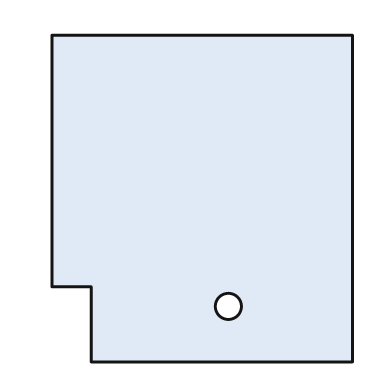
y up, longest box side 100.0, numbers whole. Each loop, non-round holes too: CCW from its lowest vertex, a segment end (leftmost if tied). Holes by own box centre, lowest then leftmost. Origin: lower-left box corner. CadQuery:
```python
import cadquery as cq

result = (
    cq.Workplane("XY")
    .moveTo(12.0, 0.0)
    .lineTo(92.0, 0.0)
    .lineTo(92.0, 100.0)
    .lineTo(0.0, 100.0)
    .lineTo(0.0, 23.0)
    .lineTo(12.0, 23.0)
    .close()
    .moveTo(54.0, 17.0)
    .circle(4.0)
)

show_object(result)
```